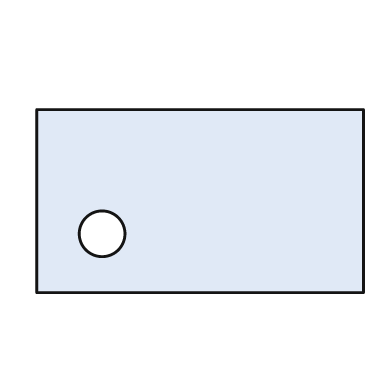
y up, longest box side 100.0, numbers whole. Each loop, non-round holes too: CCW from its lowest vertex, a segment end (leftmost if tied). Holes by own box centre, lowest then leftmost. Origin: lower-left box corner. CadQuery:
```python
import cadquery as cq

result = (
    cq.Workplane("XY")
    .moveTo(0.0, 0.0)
    .lineTo(100.0, 0.0)
    .lineTo(100.0, 56.0)
    .lineTo(0.0, 56.0)
    .close()
    .moveTo(20.0, 18.0)
    .circle(7.0)
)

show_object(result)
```